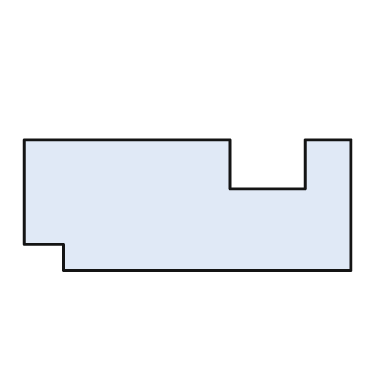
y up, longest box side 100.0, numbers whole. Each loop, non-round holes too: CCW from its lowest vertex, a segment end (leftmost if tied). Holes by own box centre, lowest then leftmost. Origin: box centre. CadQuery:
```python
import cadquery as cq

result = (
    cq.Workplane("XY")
    .moveTo(-38.0, -20.0)
    .lineTo(50.0, -20.0)
    .lineTo(50.0, 20.0)
    .lineTo(36.0, 20.0)
    .lineTo(36.0, 5.0)
    .lineTo(13.0, 5.0)
    .lineTo(13.0, 20.0)
    .lineTo(-50.0, 20.0)
    .lineTo(-50.0, -12.0)
    .lineTo(-38.0, -12.0)
    .close()
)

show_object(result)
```